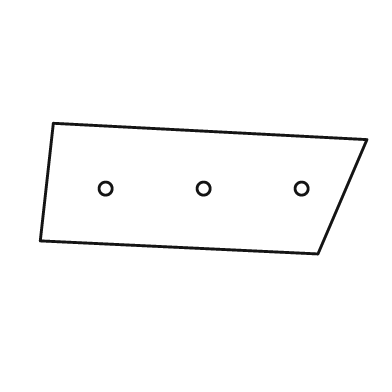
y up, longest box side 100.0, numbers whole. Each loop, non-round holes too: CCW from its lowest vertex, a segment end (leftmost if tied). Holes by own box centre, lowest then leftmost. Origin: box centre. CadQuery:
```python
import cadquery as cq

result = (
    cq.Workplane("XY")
    .moveTo(35.0, -20.0)
    .lineTo(50.0, 15.0)
    .lineTo(-46.0, 20.0)
    .lineTo(-50.0, -16.0)
    .close()
    .moveTo(-30.0, 0.0)
    .circle(2.0)
    .moveTo(0.0, 0.0)
    .circle(2.0)
    .moveTo(30.0, 0.0)
    .circle(2.0)
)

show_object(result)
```